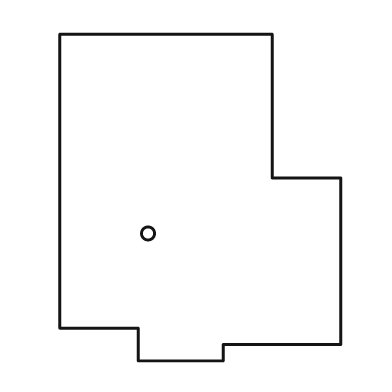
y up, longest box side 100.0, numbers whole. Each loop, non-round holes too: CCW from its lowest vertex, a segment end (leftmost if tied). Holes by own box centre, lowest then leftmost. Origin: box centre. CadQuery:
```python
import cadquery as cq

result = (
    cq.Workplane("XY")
    .moveTo(-19.0, -50.0)
    .lineTo(7.0, -50.0)
    .lineTo(7.0, -45.0)
    .lineTo(43.0, -45.0)
    .lineTo(43.0, 6.0)
    .lineTo(22.0, 6.0)
    .lineTo(22.0, 50.0)
    .lineTo(-43.0, 50.0)
    .lineTo(-43.0, -40.0)
    .lineTo(-19.0, -40.0)
    .close()
    .moveTo(-16.0, -11.0)
    .circle(2.0)
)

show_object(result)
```